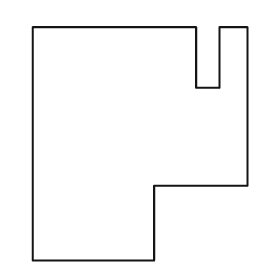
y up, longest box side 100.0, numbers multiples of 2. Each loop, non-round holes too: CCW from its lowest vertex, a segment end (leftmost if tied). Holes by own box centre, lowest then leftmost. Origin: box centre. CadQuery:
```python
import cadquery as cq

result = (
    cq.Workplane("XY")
    .moveTo(-46.0, -50.0)
    .lineTo(6.0, -50.0)
    .lineTo(6.0, -18.0)
    .lineTo(46.0, -18.0)
    .lineTo(46.0, 50.0)
    .lineTo(34.0, 50.0)
    .lineTo(34.0, 24.0)
    .lineTo(24.0, 24.0)
    .lineTo(24.0, 50.0)
    .lineTo(-46.0, 50.0)
    .close()
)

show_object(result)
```